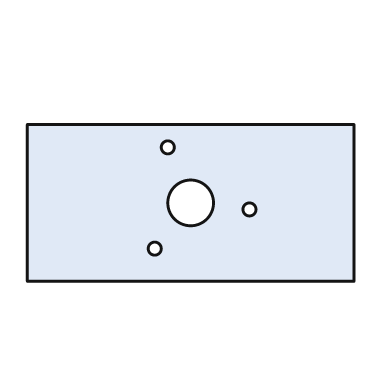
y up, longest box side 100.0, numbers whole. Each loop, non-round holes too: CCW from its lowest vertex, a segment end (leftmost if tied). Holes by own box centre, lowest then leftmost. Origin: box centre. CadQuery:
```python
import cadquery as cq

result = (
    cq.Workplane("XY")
    .moveTo(-50.0, -24.0)
    .lineTo(50.0, -24.0)
    .lineTo(50.0, 24.0)
    .lineTo(-50.0, 24.0)
    .close()
    .moveTo(-11.0, -14.0)
    .circle(2.0)
    .moveTo(18.0, -2.0)
    .circle(2.0)
    .moveTo(0.0, 0.0)
    .circle(7.0)
    .moveTo(-7.0, 17.0)
    .circle(2.0)
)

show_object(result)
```